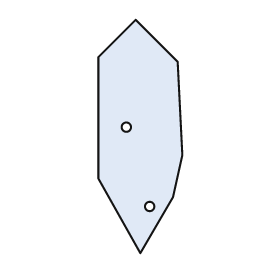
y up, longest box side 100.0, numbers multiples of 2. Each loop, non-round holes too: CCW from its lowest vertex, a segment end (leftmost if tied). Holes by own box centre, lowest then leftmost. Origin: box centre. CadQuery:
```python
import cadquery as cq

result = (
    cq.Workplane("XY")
    .moveTo(0.0, -50.0)
    .lineTo(14.0, -26.0)
    .lineTo(18.0, -8.0)
    .lineTo(16.0, 32.0)
    .lineTo(-2.0, 50.0)
    .lineTo(-18.0, 34.0)
    .lineTo(-18.0, -18.0)
    .close()
    .moveTo(4.0, -30.0)
    .circle(2.0)
    .moveTo(-6.0, 4.0)
    .circle(2.0)
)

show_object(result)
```